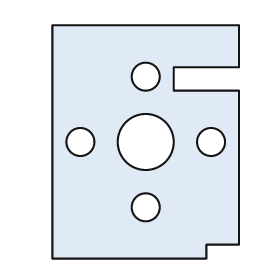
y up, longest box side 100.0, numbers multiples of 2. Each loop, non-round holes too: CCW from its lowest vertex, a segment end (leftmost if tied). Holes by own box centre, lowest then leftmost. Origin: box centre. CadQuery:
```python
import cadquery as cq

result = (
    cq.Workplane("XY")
    .moveTo(-40.0, -50.0)
    .lineTo(26.0, -50.0)
    .lineTo(26.0, -44.0)
    .lineTo(40.0, -44.0)
    .lineTo(40.0, 22.0)
    .lineTo(12.0, 22.0)
    .lineTo(12.0, 32.0)
    .lineTo(40.0, 32.0)
    .lineTo(40.0, 50.0)
    .lineTo(-40.0, 50.0)
    .close()
    .moveTo(0.0, -28.0)
    .circle(6.0)
    .moveTo(-28.0, 0.0)
    .circle(6.0)
    .moveTo(0.0, 0.0)
    .circle(12.0)
    .moveTo(28.0, 0.0)
    .circle(6.0)
    .moveTo(0.0, 28.0)
    .circle(6.0)
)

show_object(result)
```